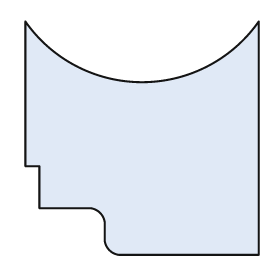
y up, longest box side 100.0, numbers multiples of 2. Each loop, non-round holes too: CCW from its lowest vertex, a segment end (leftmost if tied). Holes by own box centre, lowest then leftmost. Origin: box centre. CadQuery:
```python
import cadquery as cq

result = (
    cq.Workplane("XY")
    .moveTo(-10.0, -50.0)
    .lineTo(50.0, -50.0)
    .lineTo(50.0, 50.0)
    .threePointArc((0.0, 24.0), (-50.0, 50.0))
    .lineTo(-50.0, -12.0)
    .lineTo(-44.0, -12.0)
    .lineTo(-44.0, -30.0)
    .lineTo(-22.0, -30.0)
    .threePointArc((-18.0, -32.0), (-16.0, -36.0))
    .lineTo(-16.0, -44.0)
    .threePointArc((-14.0, -48.0), (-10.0, -50.0))
    .close()
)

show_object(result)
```